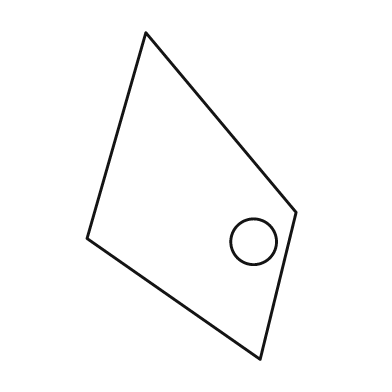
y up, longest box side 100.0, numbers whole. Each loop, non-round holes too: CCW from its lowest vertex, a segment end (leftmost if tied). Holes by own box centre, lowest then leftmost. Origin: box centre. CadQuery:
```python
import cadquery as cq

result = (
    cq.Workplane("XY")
    .moveTo(21.0, -50.0)
    .lineTo(32.0, -5.0)
    .lineTo(-14.0, 50.0)
    .lineTo(-32.0, -13.0)
    .close()
    .moveTo(19.0, -14.0)
    .circle(7.0)
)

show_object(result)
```